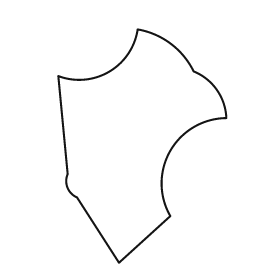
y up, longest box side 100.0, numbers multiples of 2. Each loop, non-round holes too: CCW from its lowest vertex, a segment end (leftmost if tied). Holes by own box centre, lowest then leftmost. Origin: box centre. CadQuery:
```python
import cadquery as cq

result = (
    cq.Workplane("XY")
    .moveTo(-10.0, -50.0)
    .lineTo(12.0, -30.0)
    .threePointArc((12.0, -2.0), (36.0, 12.0))
    .threePointArc((32.0, 24.0), (22.0, 32.0))
    .threePointArc((12.0, 44.0), (-2.0, 50.0))
    .threePointArc((-14.0, 32.0), (-36.0, 30.0))
    .lineTo(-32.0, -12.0)
    .threePointArc((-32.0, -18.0), (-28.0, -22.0))
    .close()
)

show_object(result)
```